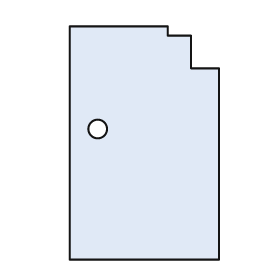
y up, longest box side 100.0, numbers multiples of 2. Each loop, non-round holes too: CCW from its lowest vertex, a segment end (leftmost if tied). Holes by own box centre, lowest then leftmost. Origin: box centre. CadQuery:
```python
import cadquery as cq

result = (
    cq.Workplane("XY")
    .moveTo(-32.0, -50.0)
    .lineTo(32.0, -50.0)
    .lineTo(32.0, 32.0)
    .lineTo(20.0, 32.0)
    .lineTo(20.0, 46.0)
    .lineTo(10.0, 46.0)
    .lineTo(10.0, 50.0)
    .lineTo(-32.0, 50.0)
    .close()
    .moveTo(-20.0, 6.0)
    .circle(4.0)
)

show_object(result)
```